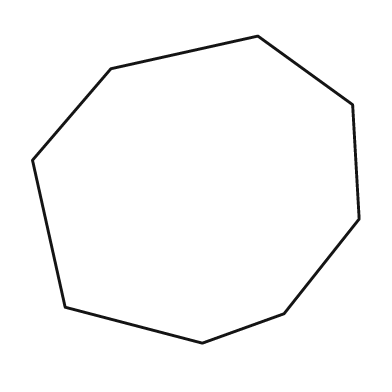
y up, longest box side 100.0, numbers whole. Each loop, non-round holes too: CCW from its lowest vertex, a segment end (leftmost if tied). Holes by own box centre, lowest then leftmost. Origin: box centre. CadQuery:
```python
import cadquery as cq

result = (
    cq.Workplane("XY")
    .moveTo(2.0, -47.0)
    .lineTo(27.0, -38.0)
    .lineTo(50.0, -9.0)
    .lineTo(48.0, 26.0)
    .lineTo(19.0, 47.0)
    .lineTo(-26.0, 37.0)
    .lineTo(-50.0, 9.0)
    .lineTo(-40.0, -36.0)
    .close()
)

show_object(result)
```